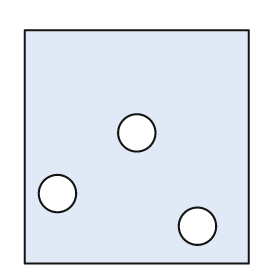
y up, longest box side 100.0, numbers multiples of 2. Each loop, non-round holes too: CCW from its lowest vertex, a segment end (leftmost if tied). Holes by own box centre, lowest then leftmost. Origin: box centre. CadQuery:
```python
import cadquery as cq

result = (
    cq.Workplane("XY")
    .moveTo(-48.0, -50.0)
    .lineTo(48.0, -50.0)
    .lineTo(48.0, 50.0)
    .lineTo(-48.0, 50.0)
    .close()
    .moveTo(26.0, -34.0)
    .circle(8.0)
    .moveTo(-34.0, -20.0)
    .circle(8.0)
    .moveTo(0.0, 6.0)
    .circle(8.0)
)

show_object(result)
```